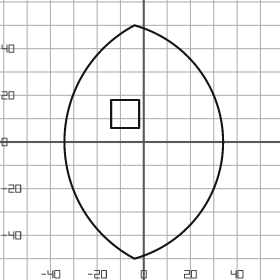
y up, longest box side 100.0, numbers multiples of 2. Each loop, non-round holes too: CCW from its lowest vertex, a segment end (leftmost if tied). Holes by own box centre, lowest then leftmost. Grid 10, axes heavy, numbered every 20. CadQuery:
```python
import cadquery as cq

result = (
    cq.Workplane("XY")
    .moveTo(-4.0, -50.0)
    .threePointArc((34.0, 0.0), (-4.0, 50.0))
    .threePointArc((-34.0, 0.0), (-4.0, -50.0))
    .close()
    .moveTo(-14.0, 6.0)
    .lineTo(-2.0, 6.0)
    .lineTo(-2.0, 18.0)
    .lineTo(-14.0, 18.0)
    .close()
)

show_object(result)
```